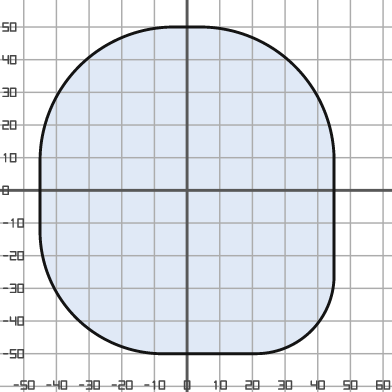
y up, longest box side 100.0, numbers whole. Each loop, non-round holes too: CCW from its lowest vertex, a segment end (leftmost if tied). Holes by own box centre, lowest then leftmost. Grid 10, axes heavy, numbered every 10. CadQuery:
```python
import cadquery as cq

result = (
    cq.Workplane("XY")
    .moveTo(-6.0, -50.0)
    .lineTo(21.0, -50.0)
    .threePointArc((38.0, -43.0), (45.0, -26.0))
    .lineTo(45.0, 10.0)
    .threePointArc((33.0, 38.0), (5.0, 50.0))
    .lineTo(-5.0, 50.0)
    .threePointArc((-33.0, 38.0), (-45.0, 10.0))
    .lineTo(-45.0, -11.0)
    .threePointArc((-34.0, -39.0), (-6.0, -50.0))
    .close()
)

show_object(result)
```